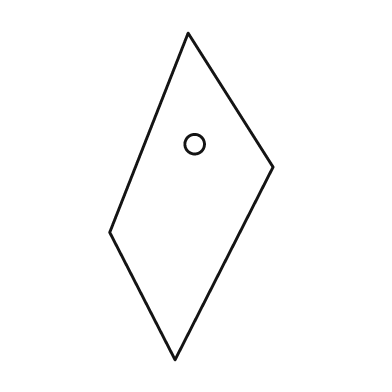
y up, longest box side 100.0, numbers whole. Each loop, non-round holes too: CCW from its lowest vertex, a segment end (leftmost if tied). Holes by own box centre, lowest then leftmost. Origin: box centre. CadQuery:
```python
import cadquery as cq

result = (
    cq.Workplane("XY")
    .moveTo(-5.0, -50.0)
    .lineTo(25.0, 9.0)
    .lineTo(-1.0, 50.0)
    .lineTo(-25.0, -11.0)
    .close()
    .moveTo(1.0, 16.0)
    .circle(3.0)
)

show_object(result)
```